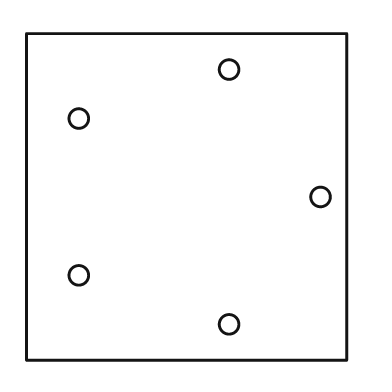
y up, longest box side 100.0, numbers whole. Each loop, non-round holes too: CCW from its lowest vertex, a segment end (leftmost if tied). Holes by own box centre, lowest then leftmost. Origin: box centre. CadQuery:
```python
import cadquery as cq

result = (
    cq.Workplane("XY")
    .moveTo(-49.0, -50.0)
    .lineTo(49.0, -50.0)
    .lineTo(49.0, 50.0)
    .lineTo(-49.0, 50.0)
    .close()
    .moveTo(13.0, -39.0)
    .circle(3.0)
    .moveTo(-33.0, -24.0)
    .circle(3.0)
    .moveTo(41.0, 0.0)
    .circle(3.0)
    .moveTo(-33.0, 24.0)
    .circle(3.0)
    .moveTo(13.0, 39.0)
    .circle(3.0)
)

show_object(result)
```